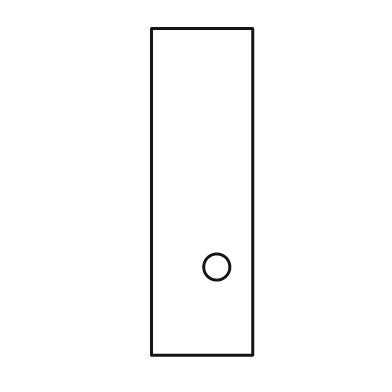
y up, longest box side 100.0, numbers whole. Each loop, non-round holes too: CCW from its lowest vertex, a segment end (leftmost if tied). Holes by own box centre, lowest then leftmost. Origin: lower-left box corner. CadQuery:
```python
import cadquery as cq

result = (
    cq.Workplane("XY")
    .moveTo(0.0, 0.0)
    .lineTo(31.0, 0.0)
    .lineTo(31.0, 100.0)
    .lineTo(0.0, 100.0)
    .close()
    .moveTo(20.0, 27.0)
    .circle(4.0)
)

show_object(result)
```